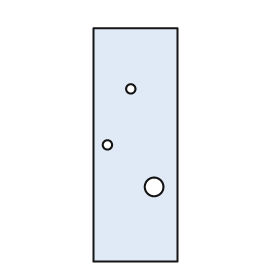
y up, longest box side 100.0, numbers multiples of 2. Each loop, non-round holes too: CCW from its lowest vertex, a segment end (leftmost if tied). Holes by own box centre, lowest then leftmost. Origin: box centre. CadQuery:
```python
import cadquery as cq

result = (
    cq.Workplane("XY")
    .moveTo(-18.0, -50.0)
    .lineTo(18.0, -50.0)
    .lineTo(18.0, 50.0)
    .lineTo(-18.0, 50.0)
    .close()
    .moveTo(8.0, -18.0)
    .circle(4.0)
    .moveTo(-12.0, 0.0)
    .circle(2.0)
    .moveTo(-2.0, 24.0)
    .circle(2.0)
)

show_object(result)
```